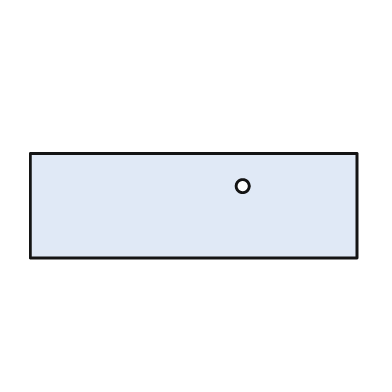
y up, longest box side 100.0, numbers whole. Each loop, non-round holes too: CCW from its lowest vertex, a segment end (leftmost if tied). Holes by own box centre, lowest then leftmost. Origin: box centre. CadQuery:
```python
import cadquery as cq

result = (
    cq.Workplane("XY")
    .moveTo(-50.0, -16.0)
    .lineTo(50.0, -16.0)
    .lineTo(50.0, 16.0)
    .lineTo(-50.0, 16.0)
    .close()
    .moveTo(15.0, 6.0)
    .circle(2.0)
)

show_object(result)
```